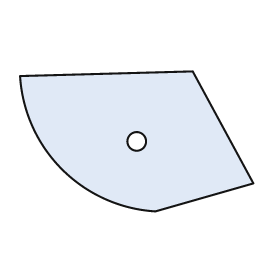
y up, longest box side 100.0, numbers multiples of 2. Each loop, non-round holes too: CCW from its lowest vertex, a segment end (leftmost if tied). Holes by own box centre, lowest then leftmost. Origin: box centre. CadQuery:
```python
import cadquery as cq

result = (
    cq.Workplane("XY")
    .moveTo(8.0, -30.0)
    .lineTo(50.0, -18.0)
    .lineTo(24.0, 30.0)
    .lineTo(-50.0, 28.0)
    .threePointArc((-32.0, -12.0), (8.0, -30.0))
    .close()
    .moveTo(0.0, 0.0)
    .circle(4.0)
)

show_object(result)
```